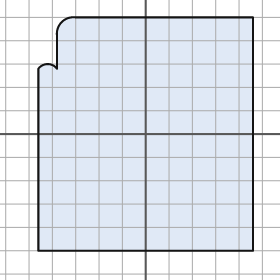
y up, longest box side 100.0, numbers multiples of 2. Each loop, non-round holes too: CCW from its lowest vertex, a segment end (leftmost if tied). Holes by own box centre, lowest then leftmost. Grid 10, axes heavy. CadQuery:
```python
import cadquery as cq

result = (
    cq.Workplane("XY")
    .moveTo(-46.0, -50.0)
    .lineTo(46.0, -50.0)
    .lineTo(46.0, 50.0)
    .lineTo(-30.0, 50.0)
    .threePointArc((-36.0, 48.0), (-38.0, 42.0))
    .lineTo(-38.0, 28.0)
    .threePointArc((-42.0, 30.0), (-46.0, 28.0))
    .close()
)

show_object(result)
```